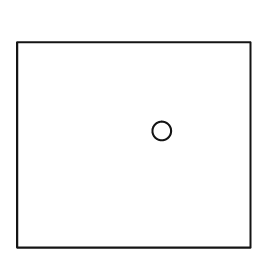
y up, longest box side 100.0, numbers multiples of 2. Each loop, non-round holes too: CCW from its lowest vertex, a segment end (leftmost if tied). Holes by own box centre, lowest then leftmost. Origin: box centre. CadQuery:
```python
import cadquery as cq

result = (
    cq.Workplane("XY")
    .moveTo(-50.0, -44.0)
    .lineTo(50.0, -44.0)
    .lineTo(50.0, 44.0)
    .lineTo(-50.0, 44.0)
    .close()
    .moveTo(12.0, 6.0)
    .circle(4.0)
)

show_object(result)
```